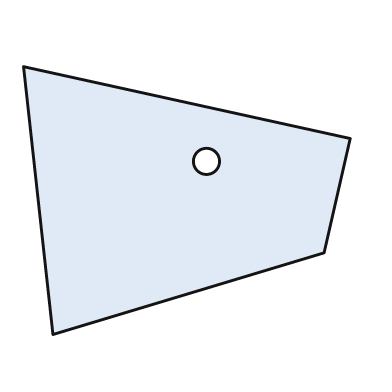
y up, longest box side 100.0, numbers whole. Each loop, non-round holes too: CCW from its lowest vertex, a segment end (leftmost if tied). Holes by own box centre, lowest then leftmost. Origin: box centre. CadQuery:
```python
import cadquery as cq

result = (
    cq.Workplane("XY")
    .moveTo(-41.0, -41.0)
    .lineTo(42.0, -16.0)
    .lineTo(50.0, 19.0)
    .lineTo(-50.0, 41.0)
    .close()
    .moveTo(6.0, 12.0)
    .circle(4.0)
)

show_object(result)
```